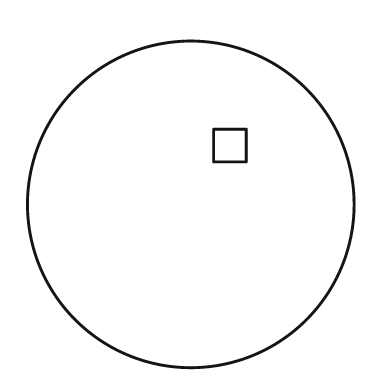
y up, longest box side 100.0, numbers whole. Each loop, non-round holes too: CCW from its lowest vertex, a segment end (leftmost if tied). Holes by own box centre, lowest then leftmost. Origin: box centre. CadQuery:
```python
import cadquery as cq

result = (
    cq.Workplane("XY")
    .moveTo(0.0, 0.0)
    .circle(50.0)
    .moveTo(7.0, 13.0)
    .lineTo(17.0, 13.0)
    .lineTo(17.0, 23.0)
    .lineTo(7.0, 23.0)
    .close()
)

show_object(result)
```